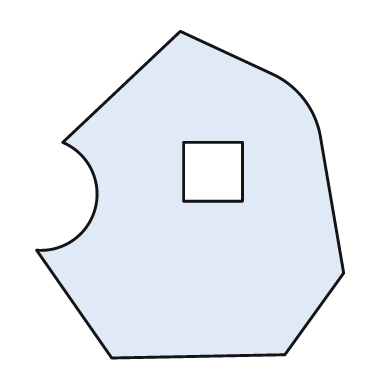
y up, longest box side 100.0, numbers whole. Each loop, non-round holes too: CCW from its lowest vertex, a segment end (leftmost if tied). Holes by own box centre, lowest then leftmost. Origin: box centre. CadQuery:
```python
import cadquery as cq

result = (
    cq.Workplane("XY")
    .moveTo(-24.0, -50.0)
    .lineTo(29.0, -49.0)
    .lineTo(47.0, -24.0)
    .lineTo(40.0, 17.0)
    .threePointArc((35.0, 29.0), (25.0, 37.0))
    .lineTo(-3.0, 50.0)
    .lineTo(-39.0, 16.0)
    .threePointArc((-29.0, -4.0), (-47.0, -17.0))
    .close()
    .moveTo(-2.0, -2.0)
    .lineTo(16.0, -2.0)
    .lineTo(16.0, 16.0)
    .lineTo(-2.0, 16.0)
    .close()
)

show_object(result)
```